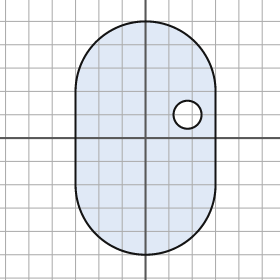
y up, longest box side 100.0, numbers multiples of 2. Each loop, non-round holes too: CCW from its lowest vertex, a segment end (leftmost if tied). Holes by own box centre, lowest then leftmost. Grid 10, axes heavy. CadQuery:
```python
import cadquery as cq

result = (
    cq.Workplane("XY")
    .moveTo(-30.0, -20.0)
    .threePointArc((0.0, -50.0), (30.0, -20.0))
    .lineTo(30.0, 20.0)
    .threePointArc((0.0, 50.0), (-30.0, 20.0))
    .close()
    .moveTo(18.0, 10.0)
    .circle(6.0)
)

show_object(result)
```